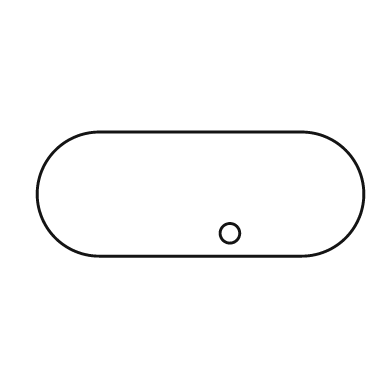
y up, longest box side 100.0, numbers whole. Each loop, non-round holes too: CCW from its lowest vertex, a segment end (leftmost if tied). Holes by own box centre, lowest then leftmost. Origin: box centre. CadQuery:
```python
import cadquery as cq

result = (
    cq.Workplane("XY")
    .moveTo(-31.0, -19.0)
    .lineTo(31.0, -19.0)
    .threePointArc((50.0, 0.0), (31.0, 19.0))
    .lineTo(-31.0, 19.0)
    .threePointArc((-50.0, 0.0), (-31.0, -19.0))
    .close()
    .moveTo(9.0, -12.0)
    .circle(3.0)
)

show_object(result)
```